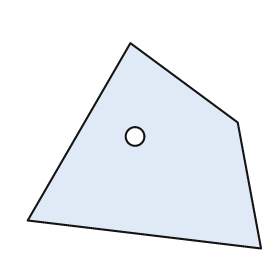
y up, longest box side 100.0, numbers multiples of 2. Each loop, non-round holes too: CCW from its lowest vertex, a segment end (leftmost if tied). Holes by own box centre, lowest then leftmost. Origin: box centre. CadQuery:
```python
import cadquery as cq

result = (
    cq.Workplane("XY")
    .moveTo(50.0, -44.0)
    .lineTo(40.0, 10.0)
    .lineTo(-6.0, 44.0)
    .lineTo(-50.0, -32.0)
    .close()
    .moveTo(-4.0, 4.0)
    .circle(4.0)
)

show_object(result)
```